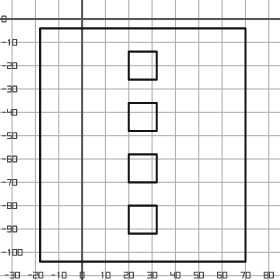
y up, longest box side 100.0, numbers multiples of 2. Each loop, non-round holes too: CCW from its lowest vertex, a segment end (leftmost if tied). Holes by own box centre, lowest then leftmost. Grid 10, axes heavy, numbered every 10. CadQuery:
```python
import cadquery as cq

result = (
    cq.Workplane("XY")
    .moveTo(-18.0, -104.0)
    .lineTo(70.0, -104.0)
    .lineTo(70.0, -4.0)
    .lineTo(-18.0, -4.0)
    .close()
    .moveTo(20.0, -92.0)
    .lineTo(32.0, -92.0)
    .lineTo(32.0, -80.0)
    .lineTo(20.0, -80.0)
    .close()
    .moveTo(20.0, -70.0)
    .lineTo(32.0, -70.0)
    .lineTo(32.0, -58.0)
    .lineTo(20.0, -58.0)
    .close()
    .moveTo(20.0, -48.0)
    .lineTo(32.0, -48.0)
    .lineTo(32.0, -36.0)
    .lineTo(20.0, -36.0)
    .close()
    .moveTo(20.0, -26.0)
    .lineTo(32.0, -26.0)
    .lineTo(32.0, -14.0)
    .lineTo(20.0, -14.0)
    .close()
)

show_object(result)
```